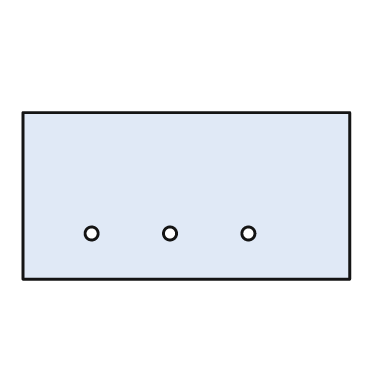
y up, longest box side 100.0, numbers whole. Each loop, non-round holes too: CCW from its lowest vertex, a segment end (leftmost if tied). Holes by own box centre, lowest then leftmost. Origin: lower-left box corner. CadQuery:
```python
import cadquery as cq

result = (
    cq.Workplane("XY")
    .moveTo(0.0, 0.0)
    .lineTo(100.0, 0.0)
    .lineTo(100.0, 51.0)
    .lineTo(0.0, 51.0)
    .close()
    .moveTo(21.0, 14.0)
    .circle(2.0)
    .moveTo(45.0, 14.0)
    .circle(2.0)
    .moveTo(69.0, 14.0)
    .circle(2.0)
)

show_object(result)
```